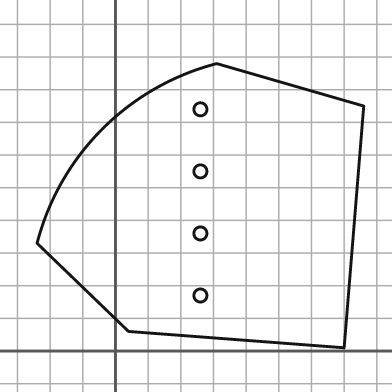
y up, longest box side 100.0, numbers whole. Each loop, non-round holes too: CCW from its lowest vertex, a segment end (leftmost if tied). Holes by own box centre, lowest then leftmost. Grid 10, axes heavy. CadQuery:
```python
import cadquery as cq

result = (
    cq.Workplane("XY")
    .moveTo(70.0, 1.0)
    .lineTo(76.0, 75.0)
    .lineTo(31.0, 88.0)
    .threePointArc((-4.0, 68.0), (-24.0, 33.0))
    .lineTo(4.0, 6.0)
    .close()
    .moveTo(26.0, 17.0)
    .circle(2.0)
    .moveTo(26.0, 36.0)
    .circle(2.0)
    .moveTo(26.0, 55.0)
    .circle(2.0)
    .moveTo(26.0, 74.0)
    .circle(2.0)
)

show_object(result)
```